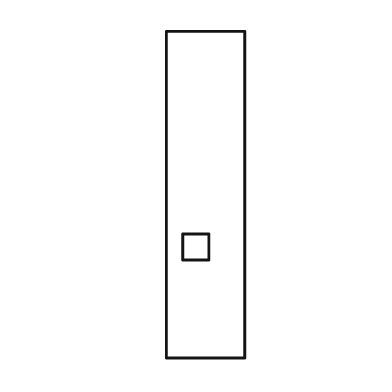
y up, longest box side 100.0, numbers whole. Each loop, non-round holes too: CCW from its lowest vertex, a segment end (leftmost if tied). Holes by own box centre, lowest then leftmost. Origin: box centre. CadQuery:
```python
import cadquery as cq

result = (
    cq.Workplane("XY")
    .moveTo(-12.0, -50.0)
    .lineTo(12.0, -50.0)
    .lineTo(12.0, 50.0)
    .lineTo(-12.0, 50.0)
    .close()
    .moveTo(-7.0, -20.0)
    .lineTo(1.0, -20.0)
    .lineTo(1.0, -12.0)
    .lineTo(-7.0, -12.0)
    .close()
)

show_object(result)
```